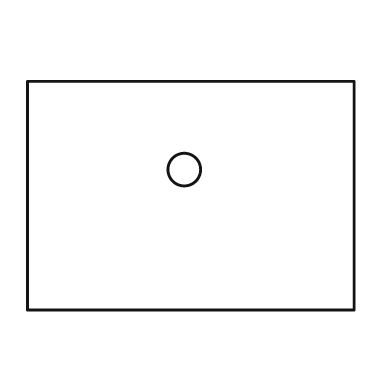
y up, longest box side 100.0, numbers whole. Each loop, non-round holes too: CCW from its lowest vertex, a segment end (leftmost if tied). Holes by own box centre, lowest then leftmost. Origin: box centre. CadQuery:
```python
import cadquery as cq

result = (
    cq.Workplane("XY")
    .moveTo(-50.0, -35.0)
    .lineTo(50.0, -35.0)
    .lineTo(50.0, 35.0)
    .lineTo(-50.0, 35.0)
    .close()
    .moveTo(-2.0, 8.0)
    .circle(5.0)
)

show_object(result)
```